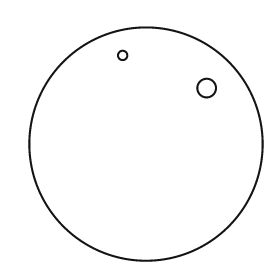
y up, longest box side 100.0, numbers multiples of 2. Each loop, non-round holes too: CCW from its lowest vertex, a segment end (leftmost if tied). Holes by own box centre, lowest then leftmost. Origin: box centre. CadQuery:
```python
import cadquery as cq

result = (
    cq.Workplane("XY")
    .moveTo(0.0, 0.0)
    .circle(50.0)
    .moveTo(26.0, 24.0)
    .circle(4.0)
    .moveTo(-10.0, 38.0)
    .circle(2.0)
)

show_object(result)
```